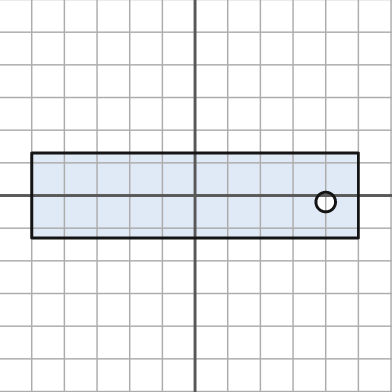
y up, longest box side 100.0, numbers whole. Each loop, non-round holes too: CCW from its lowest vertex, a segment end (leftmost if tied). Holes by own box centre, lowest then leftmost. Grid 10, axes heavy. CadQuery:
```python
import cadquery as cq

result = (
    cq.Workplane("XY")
    .moveTo(-50.0, -13.0)
    .lineTo(50.0, -13.0)
    .lineTo(50.0, 13.0)
    .lineTo(-50.0, 13.0)
    .close()
    .moveTo(40.0, -2.0)
    .circle(3.0)
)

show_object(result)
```